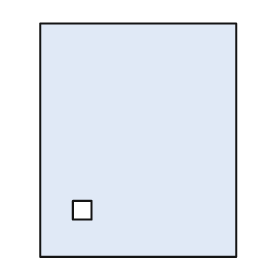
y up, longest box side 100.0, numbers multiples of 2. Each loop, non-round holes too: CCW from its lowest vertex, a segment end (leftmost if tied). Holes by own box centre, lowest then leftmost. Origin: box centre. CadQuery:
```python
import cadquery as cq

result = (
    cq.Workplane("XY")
    .moveTo(-42.0, -50.0)
    .lineTo(42.0, -50.0)
    .lineTo(42.0, 50.0)
    .lineTo(-42.0, 50.0)
    .close()
    .moveTo(-28.0, -34.0)
    .lineTo(-20.0, -34.0)
    .lineTo(-20.0, -26.0)
    .lineTo(-28.0, -26.0)
    .close()
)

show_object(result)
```